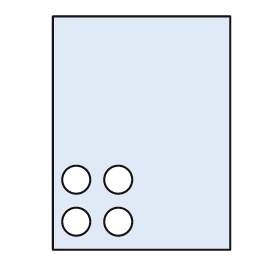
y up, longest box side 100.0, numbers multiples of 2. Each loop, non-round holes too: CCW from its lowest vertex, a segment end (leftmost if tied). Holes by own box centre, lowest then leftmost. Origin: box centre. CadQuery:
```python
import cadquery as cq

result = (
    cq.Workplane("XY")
    .moveTo(-38.0, -50.0)
    .lineTo(38.0, -50.0)
    .lineTo(38.0, 50.0)
    .lineTo(-38.0, 50.0)
    .close()
    .moveTo(-28.0, -38.0)
    .circle(6.0)
    .moveTo(-10.0, -38.0)
    .circle(6.0)
    .moveTo(-28.0, -20.0)
    .circle(6.0)
    .moveTo(-10.0, -20.0)
    .circle(6.0)
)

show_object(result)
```